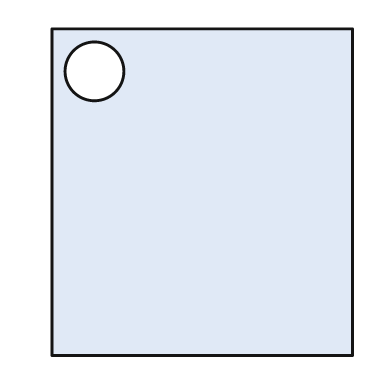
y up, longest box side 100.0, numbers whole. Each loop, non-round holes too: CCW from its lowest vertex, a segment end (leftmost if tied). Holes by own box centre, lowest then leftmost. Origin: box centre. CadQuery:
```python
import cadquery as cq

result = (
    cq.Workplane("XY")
    .moveTo(-46.0, -50.0)
    .lineTo(46.0, -50.0)
    .lineTo(46.0, 50.0)
    .lineTo(-46.0, 50.0)
    .close()
    .moveTo(-33.0, 37.0)
    .circle(9.0)
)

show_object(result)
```